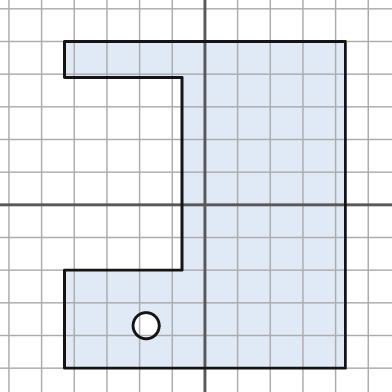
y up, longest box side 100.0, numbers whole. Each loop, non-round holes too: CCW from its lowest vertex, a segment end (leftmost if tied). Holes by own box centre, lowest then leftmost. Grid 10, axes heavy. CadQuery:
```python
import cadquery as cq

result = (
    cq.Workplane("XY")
    .moveTo(-43.0, -50.0)
    .lineTo(43.0, -50.0)
    .lineTo(43.0, 50.0)
    .lineTo(-43.0, 50.0)
    .lineTo(-43.0, 39.0)
    .lineTo(-7.0, 39.0)
    .lineTo(-7.0, -20.0)
    .lineTo(-43.0, -20.0)
    .close()
    .moveTo(-18.0, -37.0)
    .circle(4.0)
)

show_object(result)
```